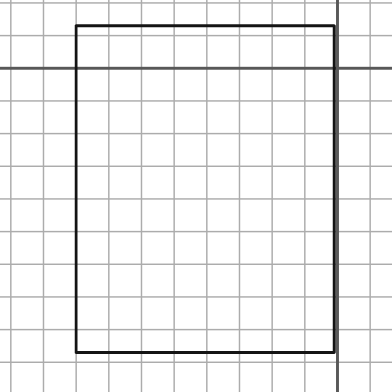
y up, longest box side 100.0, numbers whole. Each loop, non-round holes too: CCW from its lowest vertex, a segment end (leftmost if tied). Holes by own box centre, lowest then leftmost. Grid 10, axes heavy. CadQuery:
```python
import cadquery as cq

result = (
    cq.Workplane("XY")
    .moveTo(-80.0, -87.0)
    .lineTo(-1.0, -87.0)
    .lineTo(-1.0, 13.0)
    .lineTo(-80.0, 13.0)
    .close()
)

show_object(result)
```